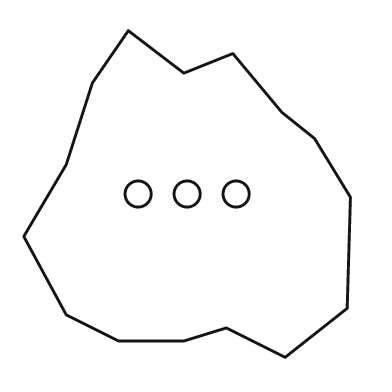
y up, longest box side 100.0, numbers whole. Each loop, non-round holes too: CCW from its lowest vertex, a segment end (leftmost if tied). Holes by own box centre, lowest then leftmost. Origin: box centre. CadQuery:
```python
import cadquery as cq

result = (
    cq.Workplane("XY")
    .moveTo(30.0, -50.0)
    .lineTo(49.0, -35.0)
    .lineTo(50.0, -1.0)
    .lineTo(39.0, 17.0)
    .lineTo(29.0, 25.0)
    .lineTo(14.0, 43.0)
    .lineTo(-1.0, 37.0)
    .lineTo(-18.0, 50.0)
    .lineTo(-29.0, 34.0)
    .lineTo(-37.0, 9.0)
    .lineTo(-50.0, -13.0)
    .lineTo(-37.0, -37.0)
    .lineTo(-21.0, -45.0)
    .lineTo(-1.0, -45.0)
    .lineTo(12.0, -41.0)
    .close()
    .moveTo(-15.0, 0.0)
    .circle(4.0)
    .moveTo(0.0, 0.0)
    .circle(4.0)
    .moveTo(15.0, 0.0)
    .circle(4.0)
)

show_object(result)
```